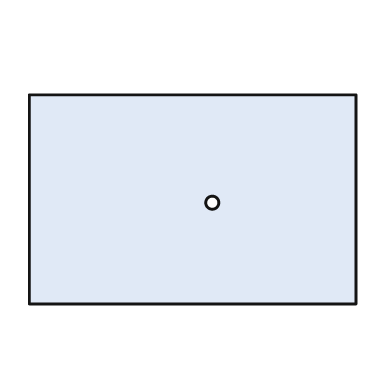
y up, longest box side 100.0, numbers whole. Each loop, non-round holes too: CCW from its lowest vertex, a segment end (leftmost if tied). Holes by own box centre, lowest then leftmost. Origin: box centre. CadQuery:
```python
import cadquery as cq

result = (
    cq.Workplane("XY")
    .moveTo(-50.0, -32.0)
    .lineTo(50.0, -32.0)
    .lineTo(50.0, 32.0)
    .lineTo(-50.0, 32.0)
    .close()
    .moveTo(6.0, -1.0)
    .circle(2.0)
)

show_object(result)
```